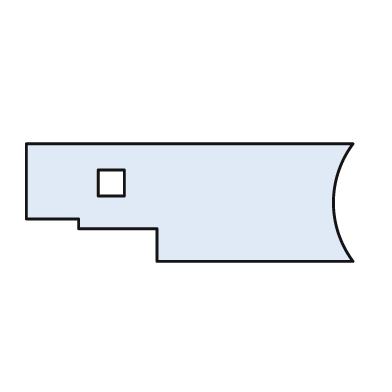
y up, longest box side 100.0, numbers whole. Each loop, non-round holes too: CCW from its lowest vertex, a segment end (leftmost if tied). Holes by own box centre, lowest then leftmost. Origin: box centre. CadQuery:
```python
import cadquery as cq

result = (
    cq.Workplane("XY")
    .moveTo(-10.0, -18.0)
    .lineTo(50.0, -18.0)
    .threePointArc((44.0, 0.0), (50.0, 18.0))
    .lineTo(-50.0, 18.0)
    .lineTo(-50.0, -5.0)
    .lineTo(-34.0, -5.0)
    .lineTo(-34.0, -8.0)
    .lineTo(-10.0, -8.0)
    .close()
    .moveTo(-28.0, 2.0)
    .lineTo(-20.0, 2.0)
    .lineTo(-20.0, 10.0)
    .lineTo(-28.0, 10.0)
    .close()
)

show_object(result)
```